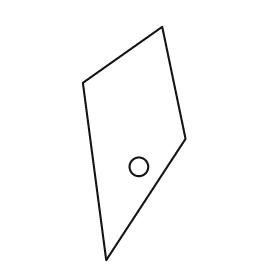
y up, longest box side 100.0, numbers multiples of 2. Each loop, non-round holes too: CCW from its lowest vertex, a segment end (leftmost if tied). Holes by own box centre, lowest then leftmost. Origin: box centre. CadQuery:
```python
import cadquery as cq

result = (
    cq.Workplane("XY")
    .moveTo(-12.0, -50.0)
    .lineTo(22.0, 2.0)
    .lineTo(12.0, 50.0)
    .lineTo(-22.0, 26.0)
    .close()
    .moveTo(2.0, -10.0)
    .circle(4.0)
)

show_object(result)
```